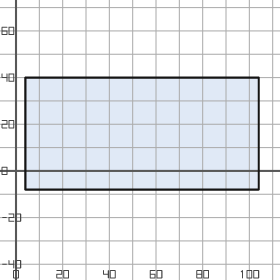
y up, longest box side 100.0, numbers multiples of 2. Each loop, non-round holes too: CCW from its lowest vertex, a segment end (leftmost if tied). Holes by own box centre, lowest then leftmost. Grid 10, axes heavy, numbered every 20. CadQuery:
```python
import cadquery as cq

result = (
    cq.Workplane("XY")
    .moveTo(4.0, -8.0)
    .lineTo(104.0, -8.0)
    .lineTo(104.0, 40.0)
    .lineTo(4.0, 40.0)
    .close()
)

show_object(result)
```